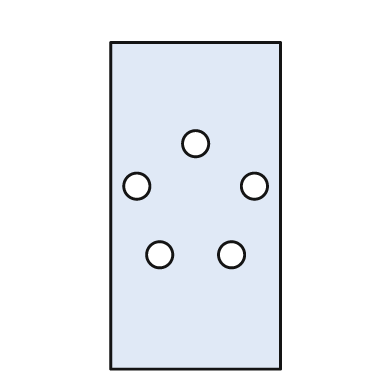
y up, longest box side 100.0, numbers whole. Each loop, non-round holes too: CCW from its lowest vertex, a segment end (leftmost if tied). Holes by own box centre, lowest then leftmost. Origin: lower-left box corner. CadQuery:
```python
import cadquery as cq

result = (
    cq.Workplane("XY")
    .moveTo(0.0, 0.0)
    .lineTo(52.0, 0.0)
    .lineTo(52.0, 100.0)
    .lineTo(0.0, 100.0)
    .close()
    .moveTo(15.0, 35.0)
    .circle(4.0)
    .moveTo(37.0, 35.0)
    .circle(4.0)
    .moveTo(8.0, 56.0)
    .circle(4.0)
    .moveTo(44.0, 56.0)
    .circle(4.0)
    .moveTo(26.0, 69.0)
    .circle(4.0)
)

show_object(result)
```